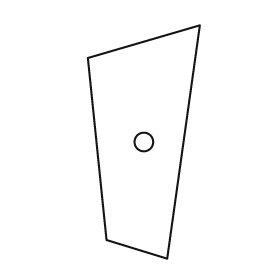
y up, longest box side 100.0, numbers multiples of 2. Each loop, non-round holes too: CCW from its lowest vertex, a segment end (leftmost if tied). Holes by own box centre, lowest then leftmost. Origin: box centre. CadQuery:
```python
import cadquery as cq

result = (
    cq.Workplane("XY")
    .moveTo(10.0, -50.0)
    .lineTo(24.0, 50.0)
    .lineTo(-24.0, 36.0)
    .lineTo(-16.0, -42.0)
    .close()
    .moveTo(0.0, 0.0)
    .circle(4.0)
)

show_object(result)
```